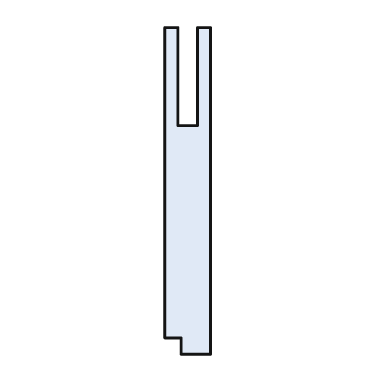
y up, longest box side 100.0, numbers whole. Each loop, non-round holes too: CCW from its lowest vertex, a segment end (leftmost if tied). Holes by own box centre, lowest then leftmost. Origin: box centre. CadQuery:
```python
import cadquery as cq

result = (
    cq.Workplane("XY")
    .moveTo(-2.0, -50.0)
    .lineTo(7.0, -50.0)
    .lineTo(7.0, 50.0)
    .lineTo(3.0, 50.0)
    .lineTo(3.0, 20.0)
    .lineTo(-3.0, 20.0)
    .lineTo(-3.0, 50.0)
    .lineTo(-7.0, 50.0)
    .lineTo(-7.0, -45.0)
    .lineTo(-2.0, -45.0)
    .close()
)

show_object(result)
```